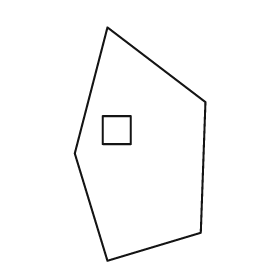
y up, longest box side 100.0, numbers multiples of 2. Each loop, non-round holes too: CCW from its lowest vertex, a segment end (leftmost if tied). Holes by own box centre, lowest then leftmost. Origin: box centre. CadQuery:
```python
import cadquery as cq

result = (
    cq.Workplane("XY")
    .moveTo(-14.0, -50.0)
    .lineTo(26.0, -38.0)
    .lineTo(28.0, 18.0)
    .lineTo(-14.0, 50.0)
    .lineTo(-28.0, -4.0)
    .close()
    .moveTo(-16.0, 0.0)
    .lineTo(-4.0, 0.0)
    .lineTo(-4.0, 12.0)
    .lineTo(-16.0, 12.0)
    .close()
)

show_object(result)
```